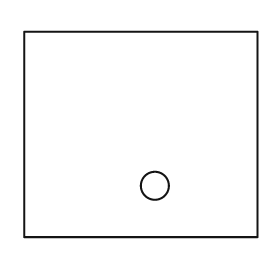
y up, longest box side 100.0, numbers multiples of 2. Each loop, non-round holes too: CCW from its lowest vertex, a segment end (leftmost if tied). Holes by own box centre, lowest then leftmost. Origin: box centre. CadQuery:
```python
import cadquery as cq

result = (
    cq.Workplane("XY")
    .moveTo(-50.0, -44.0)
    .lineTo(50.0, -44.0)
    .lineTo(50.0, 44.0)
    .lineTo(-50.0, 44.0)
    .close()
    .moveTo(6.0, -22.0)
    .circle(6.0)
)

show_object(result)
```